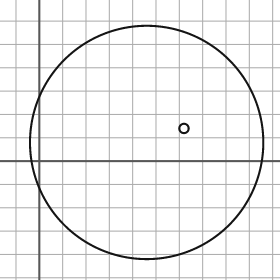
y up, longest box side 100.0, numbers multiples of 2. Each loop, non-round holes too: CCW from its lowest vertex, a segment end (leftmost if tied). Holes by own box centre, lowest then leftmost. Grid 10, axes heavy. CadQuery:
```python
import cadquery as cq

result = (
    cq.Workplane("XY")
    .moveTo(46.0, 8.0)
    .circle(50.0)
    .moveTo(62.0, 14.0)
    .circle(2.0)
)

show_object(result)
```